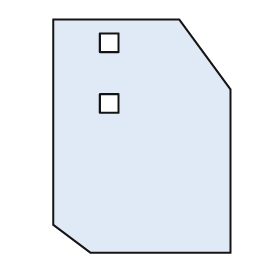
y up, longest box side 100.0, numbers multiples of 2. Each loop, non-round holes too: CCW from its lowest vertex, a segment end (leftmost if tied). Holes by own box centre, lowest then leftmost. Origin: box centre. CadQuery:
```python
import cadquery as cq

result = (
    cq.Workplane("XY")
    .moveTo(-22.0, -50.0)
    .lineTo(38.0, -50.0)
    .lineTo(38.0, 20.0)
    .lineTo(16.0, 50.0)
    .lineTo(-38.0, 50.0)
    .lineTo(-38.0, -38.0)
    .close()
    .moveTo(-18.0, 10.0)
    .lineTo(-10.0, 10.0)
    .lineTo(-10.0, 18.0)
    .lineTo(-18.0, 18.0)
    .close()
    .moveTo(-18.0, 36.0)
    .lineTo(-10.0, 36.0)
    .lineTo(-10.0, 44.0)
    .lineTo(-18.0, 44.0)
    .close()
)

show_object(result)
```